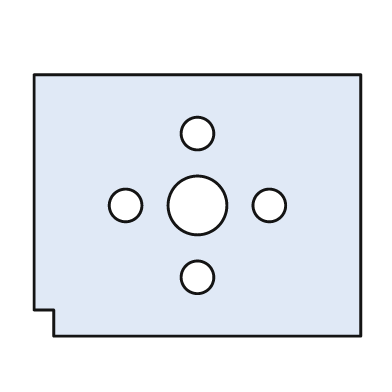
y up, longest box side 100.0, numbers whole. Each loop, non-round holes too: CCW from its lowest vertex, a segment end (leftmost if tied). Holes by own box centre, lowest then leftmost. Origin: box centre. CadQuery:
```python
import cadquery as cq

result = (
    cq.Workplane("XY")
    .moveTo(-44.0, -40.0)
    .lineTo(50.0, -40.0)
    .lineTo(50.0, 40.0)
    .lineTo(-50.0, 40.0)
    .lineTo(-50.0, -32.0)
    .lineTo(-44.0, -32.0)
    .close()
    .moveTo(0.0, -22.0)
    .circle(5.0)
    .moveTo(-22.0, 0.0)
    .circle(5.0)
    .moveTo(0.0, 0.0)
    .circle(9.0)
    .moveTo(22.0, 0.0)
    .circle(5.0)
    .moveTo(0.0, 22.0)
    .circle(5.0)
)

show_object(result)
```